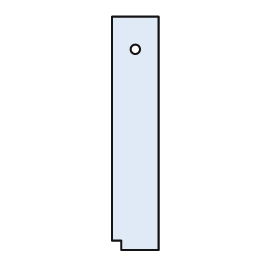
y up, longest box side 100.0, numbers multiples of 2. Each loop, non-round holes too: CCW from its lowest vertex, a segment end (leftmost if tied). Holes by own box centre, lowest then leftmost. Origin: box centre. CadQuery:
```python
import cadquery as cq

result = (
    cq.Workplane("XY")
    .moveTo(-6.0, -50.0)
    .lineTo(10.0, -50.0)
    .lineTo(10.0, 50.0)
    .lineTo(-10.0, 50.0)
    .lineTo(-10.0, -46.0)
    .lineTo(-6.0, -46.0)
    .close()
    .moveTo(0.0, 36.0)
    .circle(2.0)
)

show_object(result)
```